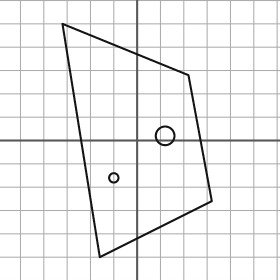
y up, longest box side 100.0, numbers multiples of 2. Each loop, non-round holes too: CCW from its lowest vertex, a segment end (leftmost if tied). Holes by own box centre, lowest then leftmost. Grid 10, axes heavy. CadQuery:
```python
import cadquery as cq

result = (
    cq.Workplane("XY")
    .moveTo(-16.0, -50.0)
    .lineTo(32.0, -26.0)
    .lineTo(22.0, 28.0)
    .lineTo(-32.0, 50.0)
    .close()
    .moveTo(-10.0, -16.0)
    .circle(2.0)
    .moveTo(12.0, 2.0)
    .circle(4.0)
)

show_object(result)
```